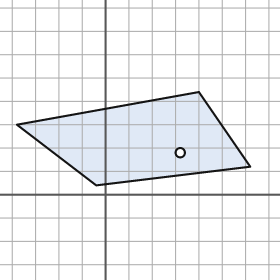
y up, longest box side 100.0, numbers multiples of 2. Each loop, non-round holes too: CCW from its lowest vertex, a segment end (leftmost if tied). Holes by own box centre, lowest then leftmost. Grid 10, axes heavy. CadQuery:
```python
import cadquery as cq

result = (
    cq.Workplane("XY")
    .moveTo(-4.0, 4.0)
    .lineTo(62.0, 12.0)
    .lineTo(40.0, 44.0)
    .lineTo(-38.0, 30.0)
    .close()
    .moveTo(32.0, 18.0)
    .circle(2.0)
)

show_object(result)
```